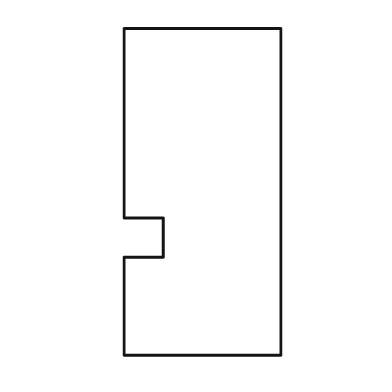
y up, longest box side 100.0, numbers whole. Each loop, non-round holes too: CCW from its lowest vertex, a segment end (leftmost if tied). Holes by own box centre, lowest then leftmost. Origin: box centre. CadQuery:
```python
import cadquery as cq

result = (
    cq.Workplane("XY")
    .moveTo(-24.0, -50.0)
    .lineTo(24.0, -50.0)
    .lineTo(24.0, 50.0)
    .lineTo(-24.0, 50.0)
    .lineTo(-24.0, -8.0)
    .lineTo(-12.0, -8.0)
    .lineTo(-12.0, -20.0)
    .lineTo(-24.0, -20.0)
    .close()
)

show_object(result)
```